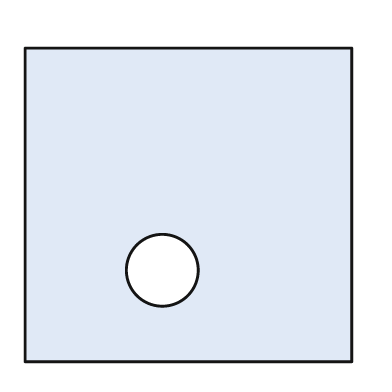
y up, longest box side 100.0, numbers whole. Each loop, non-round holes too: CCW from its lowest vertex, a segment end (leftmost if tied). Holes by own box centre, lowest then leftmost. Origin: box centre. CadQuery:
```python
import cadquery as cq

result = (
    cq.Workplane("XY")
    .moveTo(-50.0, -48.0)
    .lineTo(50.0, -48.0)
    .lineTo(50.0, 48.0)
    .lineTo(-50.0, 48.0)
    .close()
    .moveTo(-8.0, -20.0)
    .circle(11.0)
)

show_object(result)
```